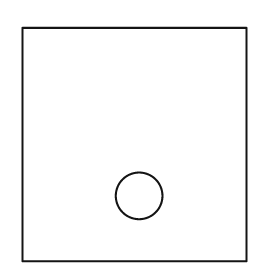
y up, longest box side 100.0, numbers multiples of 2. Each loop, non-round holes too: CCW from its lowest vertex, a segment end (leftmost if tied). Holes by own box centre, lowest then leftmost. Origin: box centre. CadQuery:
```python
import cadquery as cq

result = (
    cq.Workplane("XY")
    .moveTo(-48.0, -50.0)
    .lineTo(48.0, -50.0)
    .lineTo(48.0, 50.0)
    .lineTo(-48.0, 50.0)
    .close()
    .moveTo(2.0, -22.0)
    .circle(10.0)
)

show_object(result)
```